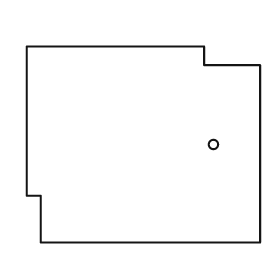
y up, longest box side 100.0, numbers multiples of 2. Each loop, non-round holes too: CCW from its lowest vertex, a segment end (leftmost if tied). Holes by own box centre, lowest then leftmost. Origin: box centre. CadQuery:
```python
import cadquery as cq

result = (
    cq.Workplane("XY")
    .moveTo(-44.0, -42.0)
    .lineTo(50.0, -42.0)
    .lineTo(50.0, 34.0)
    .lineTo(26.0, 34.0)
    .lineTo(26.0, 42.0)
    .lineTo(-50.0, 42.0)
    .lineTo(-50.0, -22.0)
    .lineTo(-44.0, -22.0)
    .close()
    .moveTo(30.0, 0.0)
    .circle(2.0)
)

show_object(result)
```